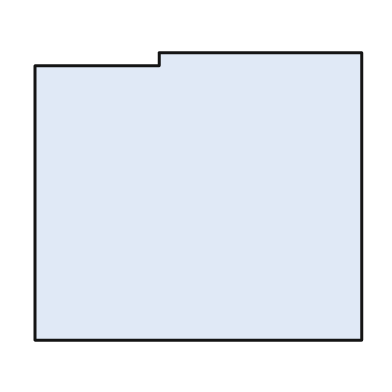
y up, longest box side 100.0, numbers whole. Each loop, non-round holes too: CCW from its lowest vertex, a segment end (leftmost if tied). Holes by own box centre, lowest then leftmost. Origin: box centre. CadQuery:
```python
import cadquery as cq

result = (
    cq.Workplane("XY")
    .moveTo(-50.0, -44.0)
    .lineTo(50.0, -44.0)
    .lineTo(50.0, 44.0)
    .lineTo(-12.0, 44.0)
    .lineTo(-12.0, 40.0)
    .lineTo(-50.0, 40.0)
    .close()
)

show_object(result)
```